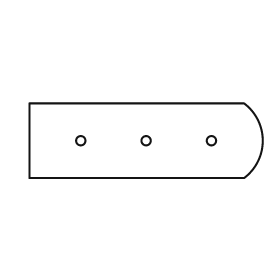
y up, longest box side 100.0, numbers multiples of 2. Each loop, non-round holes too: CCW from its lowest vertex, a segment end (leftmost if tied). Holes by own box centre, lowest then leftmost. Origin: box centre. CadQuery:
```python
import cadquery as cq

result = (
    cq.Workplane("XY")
    .moveTo(-50.0, -16.0)
    .lineTo(42.0, -16.0)
    .threePointArc((50.0, 0.0), (42.0, 16.0))
    .lineTo(-50.0, 16.0)
    .close()
    .moveTo(-28.0, 0.0)
    .circle(2.0)
    .moveTo(0.0, 0.0)
    .circle(2.0)
    .moveTo(28.0, 0.0)
    .circle(2.0)
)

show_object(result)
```